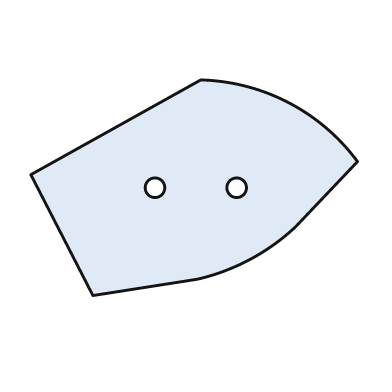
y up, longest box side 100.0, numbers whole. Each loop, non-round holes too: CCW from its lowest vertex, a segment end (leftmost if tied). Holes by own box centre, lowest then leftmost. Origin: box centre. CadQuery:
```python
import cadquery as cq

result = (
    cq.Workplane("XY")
    .moveTo(-31.0, -33.0)
    .lineTo(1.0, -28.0)
    .threePointArc((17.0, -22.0), (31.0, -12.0))
    .lineTo(50.0, 8.0)
    .threePointArc((29.0, 26.0), (2.0, 33.0))
    .lineTo(-50.0, 4.0)
    .close()
    .moveTo(-12.0, 0.0)
    .circle(3.0)
    .moveTo(13.0, 0.0)
    .circle(3.0)
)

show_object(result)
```